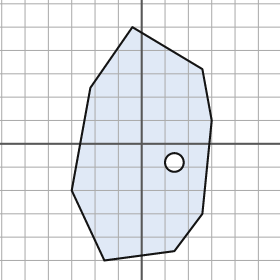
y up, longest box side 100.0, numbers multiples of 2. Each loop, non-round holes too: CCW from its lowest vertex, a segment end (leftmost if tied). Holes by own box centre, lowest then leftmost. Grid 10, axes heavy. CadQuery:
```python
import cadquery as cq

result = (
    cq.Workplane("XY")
    .moveTo(-16.0, -50.0)
    .lineTo(14.0, -46.0)
    .lineTo(26.0, -30.0)
    .lineTo(30.0, 10.0)
    .lineTo(26.0, 32.0)
    .lineTo(-4.0, 50.0)
    .lineTo(-22.0, 24.0)
    .lineTo(-30.0, -20.0)
    .close()
    .moveTo(14.0, -8.0)
    .circle(4.0)
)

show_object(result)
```